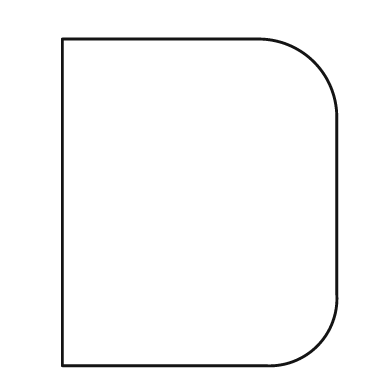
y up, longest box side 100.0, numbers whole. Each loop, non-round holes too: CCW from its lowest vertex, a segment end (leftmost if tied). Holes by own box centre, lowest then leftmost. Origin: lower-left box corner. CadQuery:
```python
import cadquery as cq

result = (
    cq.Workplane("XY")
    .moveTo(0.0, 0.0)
    .lineTo(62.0, 0.0)
    .threePointArc((78.0, 6.0), (84.0, 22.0))
    .lineTo(84.0, 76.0)
    .threePointArc((77.0, 93.0), (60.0, 100.0))
    .lineTo(0.0, 100.0)
    .close()
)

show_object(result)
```